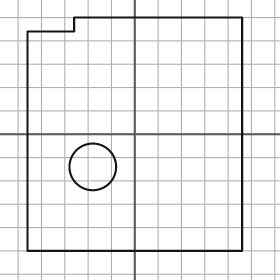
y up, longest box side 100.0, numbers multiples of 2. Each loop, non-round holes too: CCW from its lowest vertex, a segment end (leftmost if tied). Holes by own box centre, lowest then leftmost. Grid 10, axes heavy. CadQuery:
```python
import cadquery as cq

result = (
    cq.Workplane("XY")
    .moveTo(-46.0, -50.0)
    .lineTo(46.0, -50.0)
    .lineTo(46.0, 50.0)
    .lineTo(-26.0, 50.0)
    .lineTo(-26.0, 44.0)
    .lineTo(-46.0, 44.0)
    .close()
    .moveTo(-18.0, -14.0)
    .circle(10.0)
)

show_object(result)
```